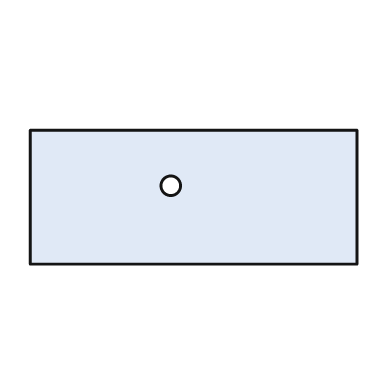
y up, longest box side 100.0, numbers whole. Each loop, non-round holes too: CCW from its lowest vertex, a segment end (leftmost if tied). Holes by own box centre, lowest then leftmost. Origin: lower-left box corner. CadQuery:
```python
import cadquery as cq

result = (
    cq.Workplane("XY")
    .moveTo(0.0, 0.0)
    .lineTo(100.0, 0.0)
    .lineTo(100.0, 41.0)
    .lineTo(0.0, 41.0)
    .close()
    .moveTo(43.0, 24.0)
    .circle(3.0)
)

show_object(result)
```